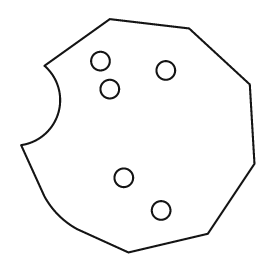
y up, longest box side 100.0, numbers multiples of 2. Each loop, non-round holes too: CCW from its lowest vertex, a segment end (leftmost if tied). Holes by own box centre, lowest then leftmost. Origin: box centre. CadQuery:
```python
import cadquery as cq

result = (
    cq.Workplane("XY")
    .moveTo(-4.0, -50.0)
    .lineTo(30.0, -42.0)
    .lineTo(50.0, -12.0)
    .lineTo(48.0, 22.0)
    .lineTo(22.0, 46.0)
    .lineTo(-12.0, 50.0)
    .lineTo(-40.0, 30.0)
    .threePointArc((-34.0, 10.0), (-50.0, -4.0))
    .lineTo(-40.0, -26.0)
    .threePointArc((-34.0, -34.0), (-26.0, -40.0))
    .close()
    .moveTo(10.0, -32.0)
    .circle(4.0)
    .moveTo(-6.0, -18.0)
    .circle(4.0)
    .moveTo(-12.0, 20.0)
    .circle(4.0)
    .moveTo(12.0, 28.0)
    .circle(4.0)
    .moveTo(-16.0, 32.0)
    .circle(4.0)
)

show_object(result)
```